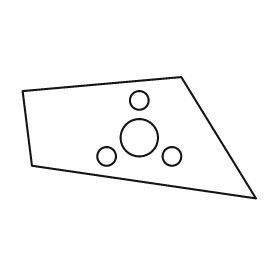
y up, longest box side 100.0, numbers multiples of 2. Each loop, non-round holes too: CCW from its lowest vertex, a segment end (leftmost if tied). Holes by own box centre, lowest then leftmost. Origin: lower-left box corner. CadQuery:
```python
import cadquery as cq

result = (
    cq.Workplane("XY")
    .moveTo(100.0, 0.0)
    .lineTo(68.0, 52.0)
    .lineTo(0.0, 46.0)
    .lineTo(4.0, 14.0)
    .close()
    .moveTo(36.0, 18.0)
    .circle(4.0)
    .moveTo(64.0, 18.0)
    .circle(4.0)
    .moveTo(50.0, 26.0)
    .circle(8.0)
    .moveTo(50.0, 42.0)
    .circle(4.0)
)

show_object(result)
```